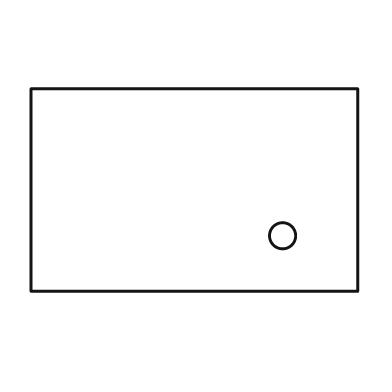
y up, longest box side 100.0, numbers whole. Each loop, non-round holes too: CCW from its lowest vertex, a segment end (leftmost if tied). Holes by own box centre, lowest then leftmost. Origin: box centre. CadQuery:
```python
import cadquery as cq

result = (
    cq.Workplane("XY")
    .moveTo(-50.0, -31.0)
    .lineTo(50.0, -31.0)
    .lineTo(50.0, 31.0)
    .lineTo(-50.0, 31.0)
    .close()
    .moveTo(27.0, -14.0)
    .circle(4.0)
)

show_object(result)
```